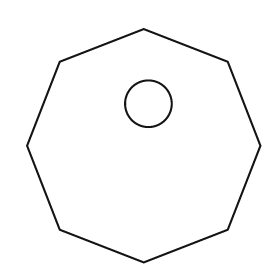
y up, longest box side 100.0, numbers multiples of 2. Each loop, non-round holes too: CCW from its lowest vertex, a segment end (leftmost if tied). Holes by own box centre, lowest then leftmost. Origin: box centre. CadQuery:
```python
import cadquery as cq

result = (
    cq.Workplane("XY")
    .moveTo(0.0, -50.0)
    .lineTo(36.0, -36.0)
    .lineTo(50.0, 0.0)
    .lineTo(36.0, 36.0)
    .lineTo(0.0, 50.0)
    .lineTo(-36.0, 36.0)
    .lineTo(-50.0, 0.0)
    .lineTo(-36.0, -36.0)
    .close()
    .moveTo(2.0, 18.0)
    .circle(10.0)
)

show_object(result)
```